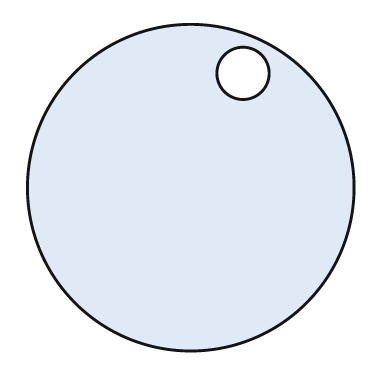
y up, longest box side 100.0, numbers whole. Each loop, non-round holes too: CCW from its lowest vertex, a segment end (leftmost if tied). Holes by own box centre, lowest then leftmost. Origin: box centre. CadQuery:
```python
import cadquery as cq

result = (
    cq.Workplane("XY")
    .moveTo(0.0, 0.0)
    .circle(50.0)
    .moveTo(16.0, 35.0)
    .circle(8.0)
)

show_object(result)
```